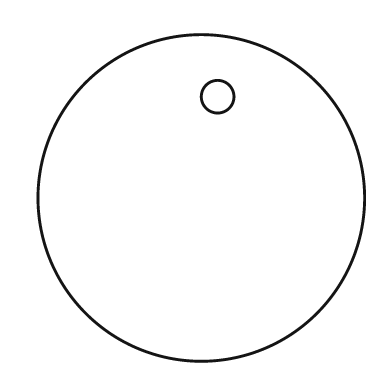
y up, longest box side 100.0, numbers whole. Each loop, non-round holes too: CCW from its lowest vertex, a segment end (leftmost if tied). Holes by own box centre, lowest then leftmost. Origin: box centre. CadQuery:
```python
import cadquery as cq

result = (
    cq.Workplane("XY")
    .moveTo(0.0, 0.0)
    .circle(50.0)
    .moveTo(5.0, 31.0)
    .circle(5.0)
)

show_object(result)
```